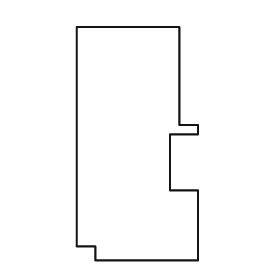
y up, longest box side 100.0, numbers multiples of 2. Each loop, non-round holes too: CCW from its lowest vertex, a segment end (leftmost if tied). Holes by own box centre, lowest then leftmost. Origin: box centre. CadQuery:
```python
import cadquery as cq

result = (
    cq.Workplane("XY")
    .moveTo(-18.0, -50.0)
    .lineTo(26.0, -50.0)
    .lineTo(26.0, -20.0)
    .lineTo(14.0, -20.0)
    .lineTo(14.0, 4.0)
    .lineTo(26.0, 4.0)
    .lineTo(26.0, 8.0)
    .lineTo(18.0, 8.0)
    .lineTo(18.0, 50.0)
    .lineTo(-26.0, 50.0)
    .lineTo(-26.0, -44.0)
    .lineTo(-18.0, -44.0)
    .close()
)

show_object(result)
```